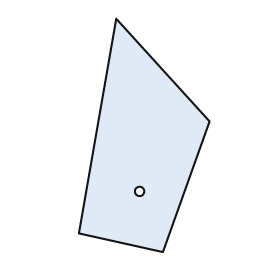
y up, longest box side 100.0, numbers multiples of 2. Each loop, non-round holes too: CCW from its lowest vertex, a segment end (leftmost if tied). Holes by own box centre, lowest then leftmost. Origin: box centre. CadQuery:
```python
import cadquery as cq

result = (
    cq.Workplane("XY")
    .moveTo(8.0, -50.0)
    .lineTo(28.0, 6.0)
    .lineTo(-12.0, 50.0)
    .lineTo(-28.0, -42.0)
    .close()
    .moveTo(-2.0, -24.0)
    .circle(2.0)
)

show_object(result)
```